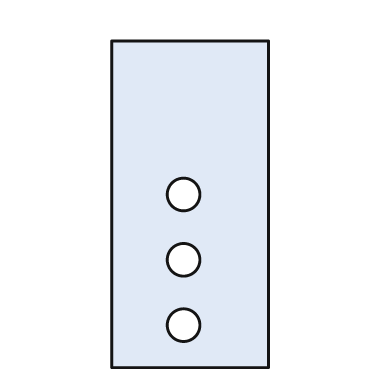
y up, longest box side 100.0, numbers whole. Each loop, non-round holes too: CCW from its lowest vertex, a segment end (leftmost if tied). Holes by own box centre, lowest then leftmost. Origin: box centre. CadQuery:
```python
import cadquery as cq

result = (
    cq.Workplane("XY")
    .moveTo(-24.0, -50.0)
    .lineTo(24.0, -50.0)
    .lineTo(24.0, 50.0)
    .lineTo(-24.0, 50.0)
    .close()
    .moveTo(-2.0, -37.0)
    .circle(5.0)
    .moveTo(-2.0, -17.0)
    .circle(5.0)
    .moveTo(-2.0, 3.0)
    .circle(5.0)
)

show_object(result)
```